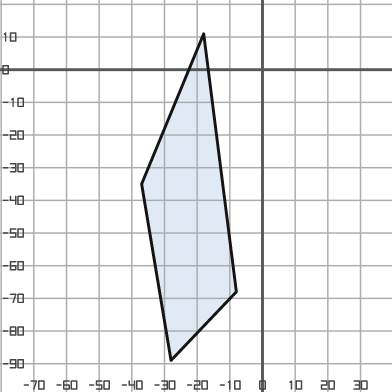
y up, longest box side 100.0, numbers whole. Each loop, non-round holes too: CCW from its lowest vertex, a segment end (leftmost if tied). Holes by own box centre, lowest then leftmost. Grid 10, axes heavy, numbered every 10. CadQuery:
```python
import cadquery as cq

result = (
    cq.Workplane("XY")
    .moveTo(-28.0, -89.0)
    .lineTo(-8.0, -68.0)
    .lineTo(-18.0, 11.0)
    .lineTo(-37.0, -35.0)
    .close()
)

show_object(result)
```